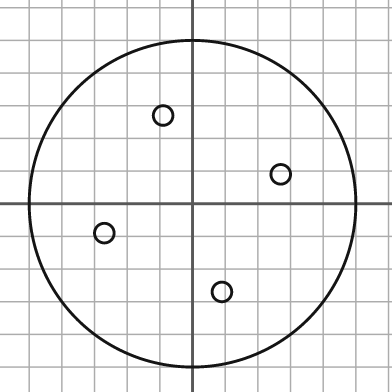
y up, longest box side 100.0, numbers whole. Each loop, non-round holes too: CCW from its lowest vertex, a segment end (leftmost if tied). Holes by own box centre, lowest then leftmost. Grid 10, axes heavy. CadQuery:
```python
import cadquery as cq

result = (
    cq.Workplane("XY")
    .moveTo(0.0, 0.0)
    .circle(50.0)
    .moveTo(9.0, -27.0)
    .circle(3.0)
    .moveTo(-27.0, -9.0)
    .circle(3.0)
    .moveTo(27.0, 9.0)
    .circle(3.0)
    .moveTo(-9.0, 27.0)
    .circle(3.0)
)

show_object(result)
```